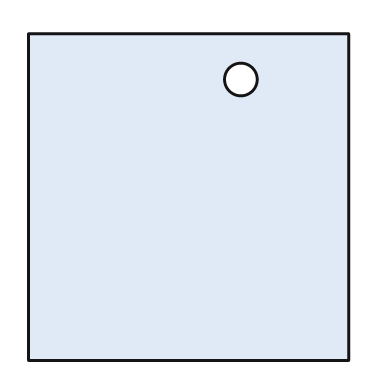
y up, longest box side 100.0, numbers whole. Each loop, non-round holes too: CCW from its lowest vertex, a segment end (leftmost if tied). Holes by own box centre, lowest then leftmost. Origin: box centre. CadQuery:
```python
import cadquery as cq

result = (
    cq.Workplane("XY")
    .moveTo(-49.0, -50.0)
    .lineTo(49.0, -50.0)
    .lineTo(49.0, 50.0)
    .lineTo(-49.0, 50.0)
    .close()
    .moveTo(16.0, 36.0)
    .circle(5.0)
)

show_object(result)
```